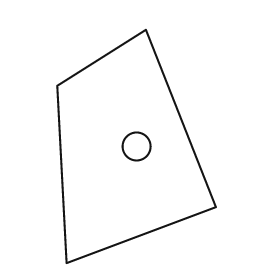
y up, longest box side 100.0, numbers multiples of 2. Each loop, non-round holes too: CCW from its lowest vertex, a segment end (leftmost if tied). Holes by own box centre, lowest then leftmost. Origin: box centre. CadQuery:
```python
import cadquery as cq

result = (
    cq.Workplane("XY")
    .moveTo(-30.0, -50.0)
    .lineTo(34.0, -26.0)
    .lineTo(4.0, 50.0)
    .lineTo(-34.0, 26.0)
    .close()
    .moveTo(0.0, 0.0)
    .circle(6.0)
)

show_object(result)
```